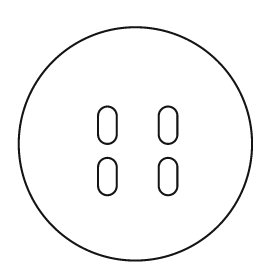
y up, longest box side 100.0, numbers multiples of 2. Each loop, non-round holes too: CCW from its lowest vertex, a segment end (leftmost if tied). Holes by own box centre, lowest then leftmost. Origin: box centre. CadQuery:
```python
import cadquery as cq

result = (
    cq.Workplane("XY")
    .moveTo(0.0, 0.0)
    .circle(50.0)
    .moveTo(-16.0, -18.0)
    .threePointArc((-12.0, -22.0), (-8.0, -18.0))
    .lineTo(-8.0, -10.0)
    .threePointArc((-12.0, -6.0), (-16.0, -10.0))
    .close()
    .moveTo(10.0, -18.0)
    .threePointArc((14.0, -22.0), (18.0, -18.0))
    .lineTo(18.0, -10.0)
    .threePointArc((14.0, -6.0), (10.0, -10.0))
    .close()
    .moveTo(-16.0, 4.0)
    .threePointArc((-12.0, 0.0), (-8.0, 4.0))
    .lineTo(-8.0, 12.0)
    .threePointArc((-12.0, 16.0), (-16.0, 12.0))
    .close()
    .moveTo(10.0, 4.0)
    .threePointArc((14.0, 0.0), (18.0, 4.0))
    .lineTo(18.0, 12.0)
    .threePointArc((14.0, 16.0), (10.0, 12.0))
    .close()
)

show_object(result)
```